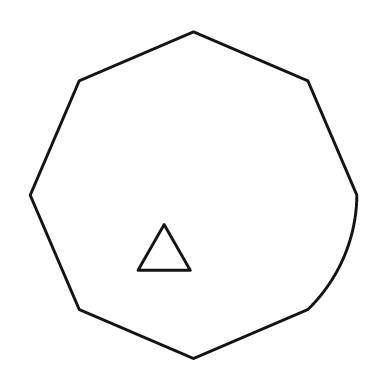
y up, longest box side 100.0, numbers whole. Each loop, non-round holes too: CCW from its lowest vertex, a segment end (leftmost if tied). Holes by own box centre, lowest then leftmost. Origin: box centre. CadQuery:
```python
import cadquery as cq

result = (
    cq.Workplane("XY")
    .moveTo(0.0, -50.0)
    .lineTo(35.0, -35.0)
    .threePointArc((46.0, -19.0), (50.0, 0.0))
    .lineTo(35.0, 35.0)
    .lineTo(0.0, 50.0)
    .lineTo(-35.0, 35.0)
    .lineTo(-50.0, 0.0)
    .lineTo(-35.0, -35.0)
    .close()
    .moveTo(-17.0, -23.0)
    .lineTo(-1.0, -23.0)
    .lineTo(-9.0, -9.0)
    .close()
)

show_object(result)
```